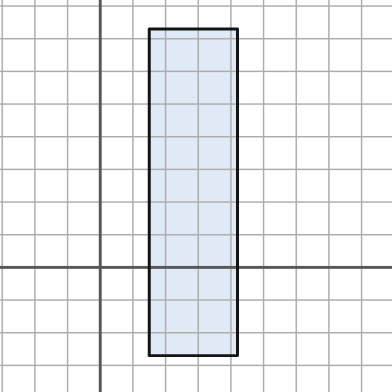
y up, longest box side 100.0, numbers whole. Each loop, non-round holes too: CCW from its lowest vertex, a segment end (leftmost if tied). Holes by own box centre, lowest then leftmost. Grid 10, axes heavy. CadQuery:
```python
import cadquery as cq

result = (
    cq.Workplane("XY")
    .moveTo(15.0, -27.0)
    .lineTo(42.0, -27.0)
    .lineTo(42.0, 73.0)
    .lineTo(15.0, 73.0)
    .close()
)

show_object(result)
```